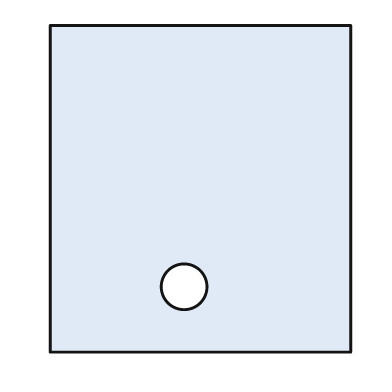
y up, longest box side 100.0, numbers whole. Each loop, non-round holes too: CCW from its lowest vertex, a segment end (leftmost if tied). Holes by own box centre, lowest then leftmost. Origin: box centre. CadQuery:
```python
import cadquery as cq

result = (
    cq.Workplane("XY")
    .moveTo(-46.0, -50.0)
    .lineTo(46.0, -50.0)
    .lineTo(46.0, 50.0)
    .lineTo(-46.0, 50.0)
    .close()
    .moveTo(-5.0, -30.0)
    .circle(7.0)
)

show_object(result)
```